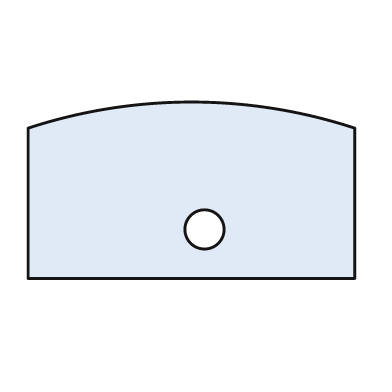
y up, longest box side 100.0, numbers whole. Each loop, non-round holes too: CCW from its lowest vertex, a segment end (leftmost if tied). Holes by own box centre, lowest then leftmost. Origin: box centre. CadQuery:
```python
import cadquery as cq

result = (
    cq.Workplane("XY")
    .moveTo(-50.0, -27.0)
    .lineTo(50.0, -27.0)
    .lineTo(50.0, 19.0)
    .threePointArc((0.0, 27.0), (-50.0, 19.0))
    .close()
    .moveTo(4.0, -12.0)
    .circle(6.0)
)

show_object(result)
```